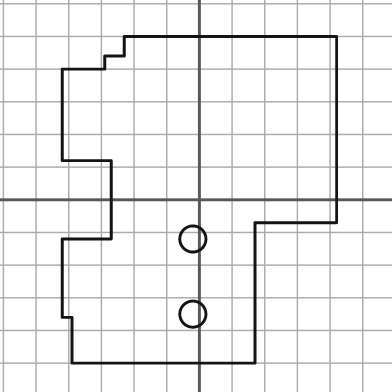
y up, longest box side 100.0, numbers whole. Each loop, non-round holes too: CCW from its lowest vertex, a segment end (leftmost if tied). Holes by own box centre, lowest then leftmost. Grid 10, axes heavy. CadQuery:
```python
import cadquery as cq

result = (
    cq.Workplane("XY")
    .moveTo(-39.0, -50.0)
    .lineTo(17.0, -50.0)
    .lineTo(17.0, -7.0)
    .lineTo(42.0, -7.0)
    .lineTo(42.0, 50.0)
    .lineTo(-23.0, 50.0)
    .lineTo(-23.0, 44.0)
    .lineTo(-29.0, 44.0)
    .lineTo(-29.0, 40.0)
    .lineTo(-42.0, 40.0)
    .lineTo(-42.0, 12.0)
    .lineTo(-27.0, 12.0)
    .lineTo(-27.0, -12.0)
    .lineTo(-42.0, -12.0)
    .lineTo(-42.0, -36.0)
    .lineTo(-39.0, -36.0)
    .close()
    .moveTo(-2.0, -35.0)
    .circle(4.0)
    .moveTo(-2.0, -12.0)
    .circle(4.0)
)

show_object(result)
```